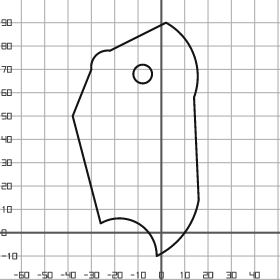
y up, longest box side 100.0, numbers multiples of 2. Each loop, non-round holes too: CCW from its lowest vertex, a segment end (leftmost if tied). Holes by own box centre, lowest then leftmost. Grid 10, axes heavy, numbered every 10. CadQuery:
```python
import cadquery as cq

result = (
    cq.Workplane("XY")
    .moveTo(-2.0, -10.0)
    .threePointArc((10.0, 0.0), (16.0, 14.0))
    .lineTo(14.0, 58.0)
    .threePointArc((14.0, 76.0), (2.0, 90.0))
    .lineTo(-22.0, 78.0)
    .threePointArc((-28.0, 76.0), (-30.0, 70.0))
    .lineTo(-38.0, 50.0)
    .lineTo(-26.0, 4.0)
    .threePointArc((-10.0, 4.0), (-2.0, -10.0))
    .close()
    .moveTo(-8.0, 68.0)
    .circle(4.0)
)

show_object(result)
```